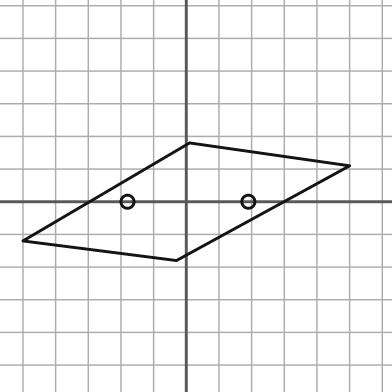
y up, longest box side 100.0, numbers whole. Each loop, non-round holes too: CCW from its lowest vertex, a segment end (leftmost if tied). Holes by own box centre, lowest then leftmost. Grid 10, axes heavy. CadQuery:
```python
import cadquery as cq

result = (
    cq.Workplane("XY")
    .moveTo(-3.0, -18.0)
    .lineTo(50.0, 11.0)
    .lineTo(1.0, 18.0)
    .lineTo(-50.0, -12.0)
    .close()
    .moveTo(-18.0, 0.0)
    .circle(2.0)
    .moveTo(19.0, 0.0)
    .circle(2.0)
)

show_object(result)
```